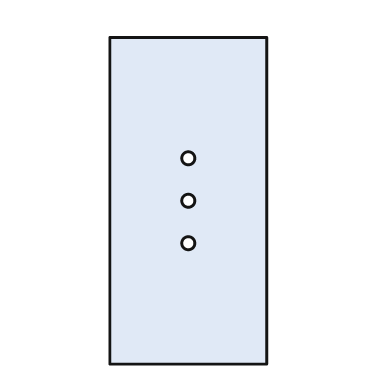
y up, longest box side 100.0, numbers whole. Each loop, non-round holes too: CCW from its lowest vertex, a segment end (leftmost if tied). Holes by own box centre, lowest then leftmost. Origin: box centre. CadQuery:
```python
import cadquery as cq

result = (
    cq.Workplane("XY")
    .moveTo(-24.0, -50.0)
    .lineTo(24.0, -50.0)
    .lineTo(24.0, 50.0)
    .lineTo(-24.0, 50.0)
    .close()
    .moveTo(0.0, -13.0)
    .circle(2.0)
    .moveTo(0.0, 0.0)
    .circle(2.0)
    .moveTo(0.0, 13.0)
    .circle(2.0)
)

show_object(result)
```